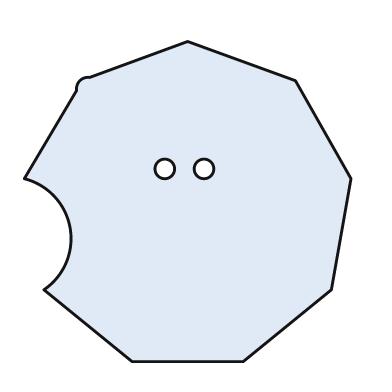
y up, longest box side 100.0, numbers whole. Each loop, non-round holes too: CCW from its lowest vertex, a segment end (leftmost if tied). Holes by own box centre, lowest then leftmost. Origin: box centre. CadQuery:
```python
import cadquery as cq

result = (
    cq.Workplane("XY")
    .moveTo(-17.0, -49.0)
    .lineTo(17.0, -49.0)
    .lineTo(44.0, -27.0)
    .lineTo(50.0, 7.0)
    .lineTo(33.0, 37.0)
    .lineTo(0.0, 49.0)
    .lineTo(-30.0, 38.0)
    .threePointArc((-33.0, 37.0), (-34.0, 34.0))
    .lineTo(-50.0, 7.0)
    .threePointArc((-36.0, -8.0), (-44.0, -27.0))
    .close()
    .moveTo(-7.0, 10.0)
    .circle(3.0)
    .moveTo(5.0, 10.0)
    .circle(3.0)
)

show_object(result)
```